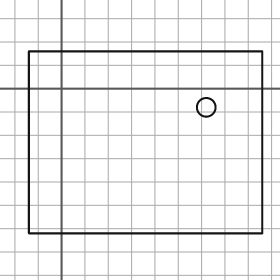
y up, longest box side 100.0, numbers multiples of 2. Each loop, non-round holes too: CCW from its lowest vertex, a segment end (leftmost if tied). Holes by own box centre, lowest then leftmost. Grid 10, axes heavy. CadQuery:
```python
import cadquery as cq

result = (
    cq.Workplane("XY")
    .moveTo(-14.0, -62.0)
    .lineTo(86.0, -62.0)
    .lineTo(86.0, 16.0)
    .lineTo(-14.0, 16.0)
    .close()
    .moveTo(62.0, -8.0)
    .circle(4.0)
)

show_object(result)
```